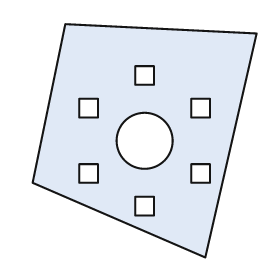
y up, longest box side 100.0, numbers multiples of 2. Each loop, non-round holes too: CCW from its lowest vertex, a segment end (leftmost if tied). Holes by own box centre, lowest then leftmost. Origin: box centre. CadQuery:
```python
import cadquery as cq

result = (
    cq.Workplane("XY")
    .moveTo(26.0, -50.0)
    .lineTo(48.0, 46.0)
    .lineTo(-34.0, 50.0)
    .lineTo(-48.0, -18.0)
    .close()
    .moveTo(-4.0, -32.0)
    .lineTo(4.0, -32.0)
    .lineTo(4.0, -24.0)
    .lineTo(-4.0, -24.0)
    .close()
    .moveTo(-28.0, -18.0)
    .lineTo(-20.0, -18.0)
    .lineTo(-20.0, -10.0)
    .lineTo(-28.0, -10.0)
    .close()
    .moveTo(20.0, -18.0)
    .lineTo(28.0, -18.0)
    .lineTo(28.0, -10.0)
    .lineTo(20.0, -10.0)
    .close()
    .moveTo(0.0, 0.0)
    .circle(12.0)
    .moveTo(-28.0, 10.0)
    .lineTo(-20.0, 10.0)
    .lineTo(-20.0, 18.0)
    .lineTo(-28.0, 18.0)
    .close()
    .moveTo(20.0, 10.0)
    .lineTo(28.0, 10.0)
    .lineTo(28.0, 18.0)
    .lineTo(20.0, 18.0)
    .close()
    .moveTo(-4.0, 24.0)
    .lineTo(4.0, 24.0)
    .lineTo(4.0, 32.0)
    .lineTo(-4.0, 32.0)
    .close()
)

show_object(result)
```